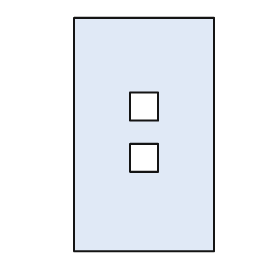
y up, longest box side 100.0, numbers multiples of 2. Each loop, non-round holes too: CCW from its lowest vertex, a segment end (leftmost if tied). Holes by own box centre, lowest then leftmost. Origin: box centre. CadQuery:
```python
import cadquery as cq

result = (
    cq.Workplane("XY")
    .moveTo(-30.0, -50.0)
    .lineTo(30.0, -50.0)
    .lineTo(30.0, 50.0)
    .lineTo(-30.0, 50.0)
    .close()
    .moveTo(-6.0, -16.0)
    .lineTo(6.0, -16.0)
    .lineTo(6.0, -4.0)
    .lineTo(-6.0, -4.0)
    .close()
    .moveTo(-6.0, 6.0)
    .lineTo(6.0, 6.0)
    .lineTo(6.0, 18.0)
    .lineTo(-6.0, 18.0)
    .close()
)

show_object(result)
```